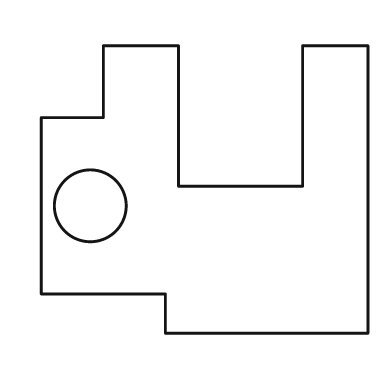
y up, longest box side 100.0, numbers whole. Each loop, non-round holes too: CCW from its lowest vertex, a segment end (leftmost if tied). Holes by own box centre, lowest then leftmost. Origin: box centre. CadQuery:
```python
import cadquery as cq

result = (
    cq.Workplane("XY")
    .moveTo(-12.0, -44.0)
    .lineTo(50.0, -44.0)
    .lineTo(50.0, 44.0)
    .lineTo(30.0, 44.0)
    .lineTo(30.0, 1.0)
    .lineTo(-8.0, 1.0)
    .lineTo(-8.0, 44.0)
    .lineTo(-31.0, 44.0)
    .lineTo(-31.0, 22.0)
    .lineTo(-50.0, 22.0)
    .lineTo(-50.0, -32.0)
    .lineTo(-12.0, -32.0)
    .close()
    .moveTo(-35.0, -5.0)
    .circle(11.0)
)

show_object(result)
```